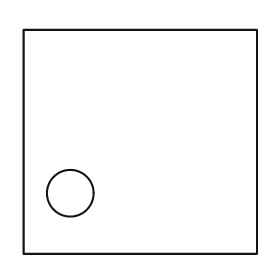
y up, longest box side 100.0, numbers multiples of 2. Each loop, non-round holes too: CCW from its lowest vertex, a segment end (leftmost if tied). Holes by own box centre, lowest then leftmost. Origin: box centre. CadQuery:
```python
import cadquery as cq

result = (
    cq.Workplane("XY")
    .moveTo(-50.0, -48.0)
    .lineTo(50.0, -48.0)
    .lineTo(50.0, 48.0)
    .lineTo(-50.0, 48.0)
    .close()
    .moveTo(-30.0, -22.0)
    .circle(10.0)
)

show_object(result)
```